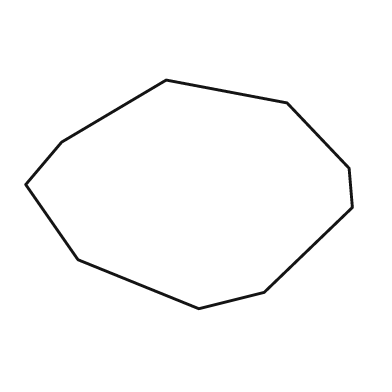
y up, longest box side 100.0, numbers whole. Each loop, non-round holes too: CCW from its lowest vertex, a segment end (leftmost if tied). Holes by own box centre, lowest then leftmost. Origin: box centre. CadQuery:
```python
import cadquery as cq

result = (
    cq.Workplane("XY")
    .moveTo(3.0, -35.0)
    .lineTo(23.0, -30.0)
    .lineTo(50.0, -4.0)
    .lineTo(49.0, 8.0)
    .lineTo(30.0, 28.0)
    .lineTo(-7.0, 35.0)
    .lineTo(-39.0, 16.0)
    .lineTo(-50.0, 3.0)
    .lineTo(-34.0, -20.0)
    .close()
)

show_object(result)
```